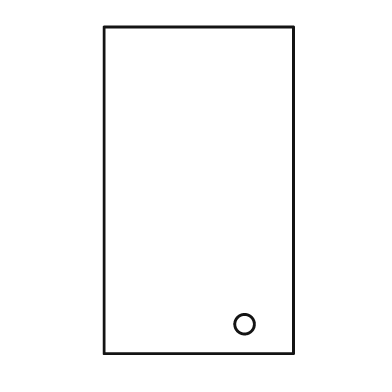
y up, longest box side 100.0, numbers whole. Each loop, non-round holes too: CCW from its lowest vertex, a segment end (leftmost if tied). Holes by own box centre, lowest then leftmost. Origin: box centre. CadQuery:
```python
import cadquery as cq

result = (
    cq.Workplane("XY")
    .moveTo(-29.0, -50.0)
    .lineTo(29.0, -50.0)
    .lineTo(29.0, 50.0)
    .lineTo(-29.0, 50.0)
    .close()
    .moveTo(14.0, -41.0)
    .circle(3.0)
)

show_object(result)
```